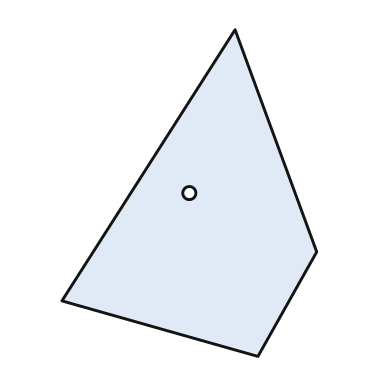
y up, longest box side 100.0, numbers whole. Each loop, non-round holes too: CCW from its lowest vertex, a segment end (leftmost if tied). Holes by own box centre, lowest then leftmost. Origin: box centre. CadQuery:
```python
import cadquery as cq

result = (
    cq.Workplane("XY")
    .moveTo(21.0, -50.0)
    .lineTo(39.0, -18.0)
    .lineTo(14.0, 50.0)
    .lineTo(-39.0, -33.0)
    .close()
    .moveTo(0.0, 0.0)
    .circle(2.0)
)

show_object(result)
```